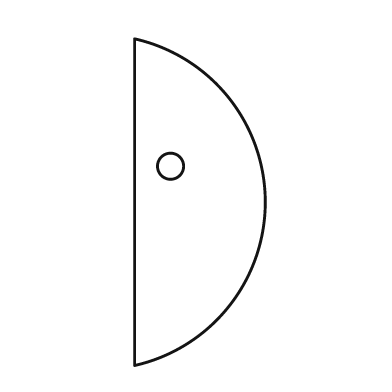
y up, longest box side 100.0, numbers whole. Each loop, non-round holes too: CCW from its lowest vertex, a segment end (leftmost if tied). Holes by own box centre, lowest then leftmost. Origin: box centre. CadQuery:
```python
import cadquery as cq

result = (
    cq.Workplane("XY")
    .moveTo(-20.0, -50.0)
    .threePointArc((20.0, 0.0), (-20.0, 50.0))
    .close()
    .moveTo(-9.0, 11.0)
    .circle(4.0)
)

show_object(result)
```